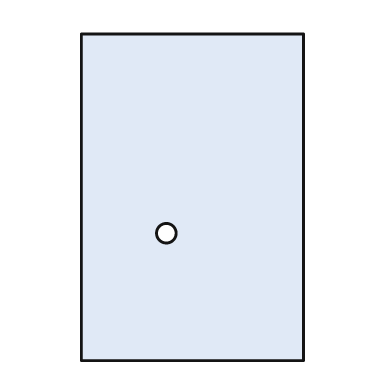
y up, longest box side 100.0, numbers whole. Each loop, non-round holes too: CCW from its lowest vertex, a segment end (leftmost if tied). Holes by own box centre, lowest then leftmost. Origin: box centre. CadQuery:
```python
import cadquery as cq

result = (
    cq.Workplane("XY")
    .moveTo(-34.0, -50.0)
    .lineTo(34.0, -50.0)
    .lineTo(34.0, 50.0)
    .lineTo(-34.0, 50.0)
    .close()
    .moveTo(-8.0, -11.0)
    .circle(3.0)
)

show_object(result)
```